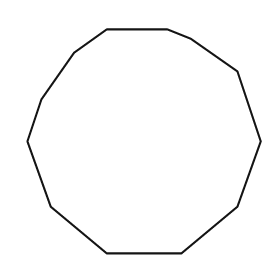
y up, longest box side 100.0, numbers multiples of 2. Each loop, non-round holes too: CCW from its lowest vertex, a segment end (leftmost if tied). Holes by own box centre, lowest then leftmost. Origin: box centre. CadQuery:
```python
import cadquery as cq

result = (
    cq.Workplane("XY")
    .moveTo(-16.0, -48.0)
    .lineTo(16.0, -48.0)
    .lineTo(40.0, -28.0)
    .lineTo(50.0, 0.0)
    .lineTo(40.0, 30.0)
    .lineTo(20.0, 44.0)
    .lineTo(10.0, 48.0)
    .lineTo(-16.0, 48.0)
    .lineTo(-30.0, 38.0)
    .lineTo(-44.0, 18.0)
    .lineTo(-50.0, 0.0)
    .lineTo(-40.0, -28.0)
    .close()
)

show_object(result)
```